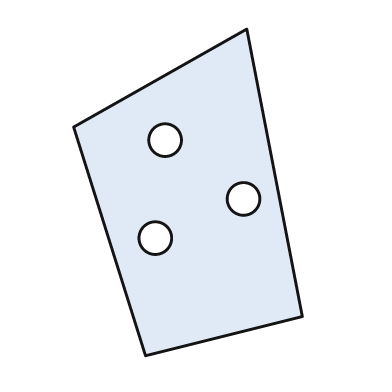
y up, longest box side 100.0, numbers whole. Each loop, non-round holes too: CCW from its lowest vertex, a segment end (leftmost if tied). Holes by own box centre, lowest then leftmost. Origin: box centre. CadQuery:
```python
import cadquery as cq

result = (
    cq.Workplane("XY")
    .moveTo(-13.0, -50.0)
    .lineTo(35.0, -38.0)
    .lineTo(18.0, 50.0)
    .lineTo(-35.0, 20.0)
    .close()
    .moveTo(-10.0, -14.0)
    .circle(5.0)
    .moveTo(17.0, -2.0)
    .circle(5.0)
    .moveTo(-7.0, 16.0)
    .circle(5.0)
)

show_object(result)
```